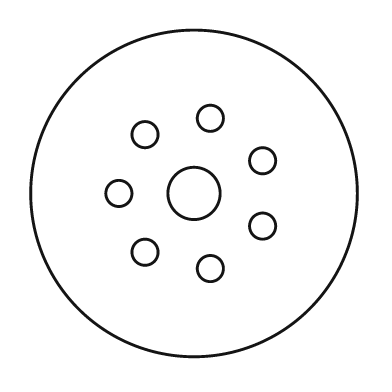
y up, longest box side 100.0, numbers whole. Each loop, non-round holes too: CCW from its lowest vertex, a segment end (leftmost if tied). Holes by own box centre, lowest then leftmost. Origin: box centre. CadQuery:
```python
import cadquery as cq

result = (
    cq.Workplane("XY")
    .moveTo(0.0, 0.0)
    .circle(50.0)
    .moveTo(5.0, -23.0)
    .circle(4.0)
    .moveTo(-15.0, -18.0)
    .circle(4.0)
    .moveTo(21.0, -10.0)
    .circle(4.0)
    .moveTo(-23.0, 0.0)
    .circle(4.0)
    .moveTo(0.0, 0.0)
    .circle(8.0)
    .moveTo(21.0, 10.0)
    .circle(4.0)
    .moveTo(-15.0, 18.0)
    .circle(4.0)
    .moveTo(5.0, 23.0)
    .circle(4.0)
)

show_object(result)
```